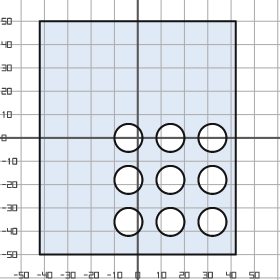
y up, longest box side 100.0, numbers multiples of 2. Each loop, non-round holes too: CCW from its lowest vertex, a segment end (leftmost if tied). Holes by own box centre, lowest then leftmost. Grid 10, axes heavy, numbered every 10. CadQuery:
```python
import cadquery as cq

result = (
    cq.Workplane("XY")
    .moveTo(-42.0, -50.0)
    .lineTo(42.0, -50.0)
    .lineTo(42.0, 50.0)
    .lineTo(-42.0, 50.0)
    .close()
    .moveTo(-4.0, -36.0)
    .circle(6.0)
    .moveTo(14.0, -36.0)
    .circle(6.0)
    .moveTo(32.0, -36.0)
    .circle(6.0)
    .moveTo(-4.0, -18.0)
    .circle(6.0)
    .moveTo(14.0, -18.0)
    .circle(6.0)
    .moveTo(32.0, -18.0)
    .circle(6.0)
    .moveTo(-4.0, 0.0)
    .circle(6.0)
    .moveTo(14.0, 0.0)
    .circle(6.0)
    .moveTo(32.0, 0.0)
    .circle(6.0)
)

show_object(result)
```